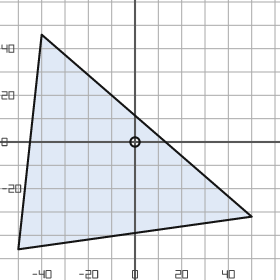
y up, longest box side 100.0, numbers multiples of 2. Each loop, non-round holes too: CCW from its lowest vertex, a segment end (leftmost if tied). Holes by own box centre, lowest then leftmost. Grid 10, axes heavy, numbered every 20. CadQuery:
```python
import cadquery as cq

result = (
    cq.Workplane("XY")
    .moveTo(-50.0, -46.0)
    .lineTo(50.0, -32.0)
    .lineTo(-40.0, 46.0)
    .close()
    .moveTo(0.0, 0.0)
    .circle(2.0)
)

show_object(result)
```